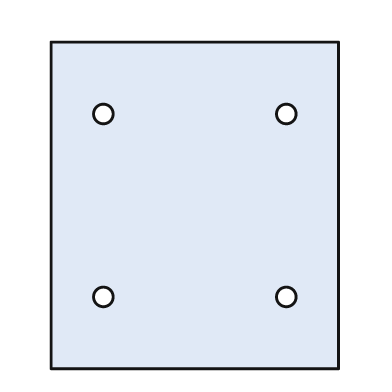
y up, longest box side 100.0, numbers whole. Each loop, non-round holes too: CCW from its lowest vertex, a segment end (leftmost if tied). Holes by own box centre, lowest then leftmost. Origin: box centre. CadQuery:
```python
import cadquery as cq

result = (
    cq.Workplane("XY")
    .moveTo(-44.0, -50.0)
    .lineTo(44.0, -50.0)
    .lineTo(44.0, 50.0)
    .lineTo(-44.0, 50.0)
    .close()
    .moveTo(-28.0, -28.0)
    .circle(3.0)
    .moveTo(28.0, -28.0)
    .circle(3.0)
    .moveTo(-28.0, 28.0)
    .circle(3.0)
    .moveTo(28.0, 28.0)
    .circle(3.0)
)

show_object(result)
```